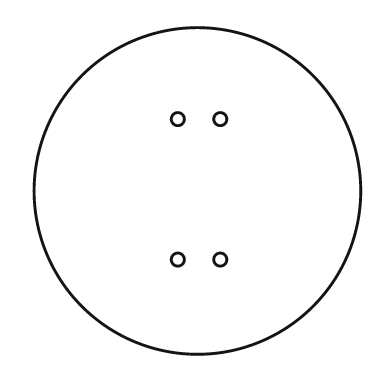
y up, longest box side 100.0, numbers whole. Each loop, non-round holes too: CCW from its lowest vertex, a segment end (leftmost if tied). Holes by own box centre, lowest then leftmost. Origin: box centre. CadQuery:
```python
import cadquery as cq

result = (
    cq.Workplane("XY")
    .moveTo(0.0, 0.0)
    .circle(50.0)
    .moveTo(-6.0, -21.0)
    .circle(2.0)
    .moveTo(7.0, -21.0)
    .circle(2.0)
    .moveTo(-6.0, 22.0)
    .circle(2.0)
    .moveTo(7.0, 22.0)
    .circle(2.0)
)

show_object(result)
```